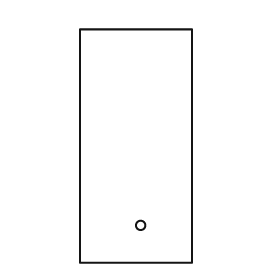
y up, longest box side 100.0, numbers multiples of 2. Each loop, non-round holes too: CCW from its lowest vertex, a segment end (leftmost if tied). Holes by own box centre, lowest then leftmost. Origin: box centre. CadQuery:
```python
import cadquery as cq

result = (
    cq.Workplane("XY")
    .moveTo(-24.0, -50.0)
    .lineTo(24.0, -50.0)
    .lineTo(24.0, 50.0)
    .lineTo(-24.0, 50.0)
    .close()
    .moveTo(2.0, -34.0)
    .circle(2.0)
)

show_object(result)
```